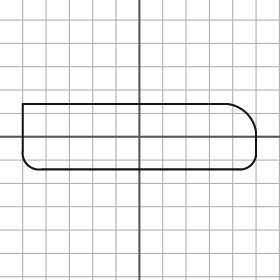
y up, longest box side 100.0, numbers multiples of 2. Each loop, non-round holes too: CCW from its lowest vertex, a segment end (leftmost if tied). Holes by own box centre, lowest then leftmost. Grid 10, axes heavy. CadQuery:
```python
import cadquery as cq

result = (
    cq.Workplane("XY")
    .moveTo(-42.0, -14.0)
    .lineTo(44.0, -14.0)
    .threePointArc((48.0, -12.0), (50.0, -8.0))
    .lineTo(50.0, 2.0)
    .threePointArc((46.0, 10.0), (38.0, 14.0))
    .lineTo(-50.0, 14.0)
    .lineTo(-50.0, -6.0)
    .threePointArc((-48.0, -12.0), (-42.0, -14.0))
    .close()
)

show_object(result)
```